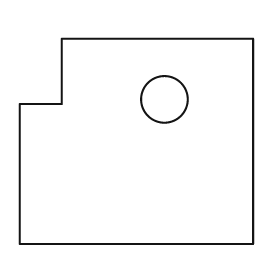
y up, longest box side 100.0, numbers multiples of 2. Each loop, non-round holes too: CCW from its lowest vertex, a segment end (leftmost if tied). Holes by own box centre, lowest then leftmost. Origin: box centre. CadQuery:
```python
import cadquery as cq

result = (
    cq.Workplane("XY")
    .moveTo(-50.0, -44.0)
    .lineTo(50.0, -44.0)
    .lineTo(50.0, 44.0)
    .lineTo(-32.0, 44.0)
    .lineTo(-32.0, 16.0)
    .lineTo(-50.0, 16.0)
    .close()
    .moveTo(12.0, 18.0)
    .circle(10.0)
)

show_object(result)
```